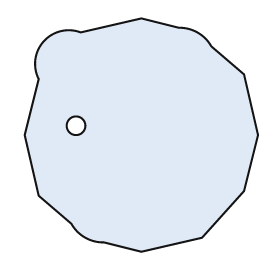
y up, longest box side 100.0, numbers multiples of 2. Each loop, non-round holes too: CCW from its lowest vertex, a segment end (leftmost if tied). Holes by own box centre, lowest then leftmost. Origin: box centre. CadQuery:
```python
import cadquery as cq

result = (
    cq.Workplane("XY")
    .moveTo(0.0, -50.0)
    .lineTo(26.0, -44.0)
    .lineTo(44.0, -24.0)
    .lineTo(50.0, 0.0)
    .lineTo(44.0, 26.0)
    .lineTo(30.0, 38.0)
    .threePointArc((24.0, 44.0), (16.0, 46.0))
    .lineTo(0.0, 50.0)
    .lineTo(-26.0, 44.0)
    .threePointArc((-42.0, 40.0), (-44.0, 24.0))
    .lineTo(-50.0, 0.0)
    .lineTo(-44.0, -26.0)
    .lineTo(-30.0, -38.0)
    .threePointArc((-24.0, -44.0), (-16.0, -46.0))
    .close()
    .moveTo(-28.0, 4.0)
    .circle(4.0)
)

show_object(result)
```